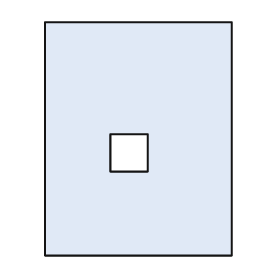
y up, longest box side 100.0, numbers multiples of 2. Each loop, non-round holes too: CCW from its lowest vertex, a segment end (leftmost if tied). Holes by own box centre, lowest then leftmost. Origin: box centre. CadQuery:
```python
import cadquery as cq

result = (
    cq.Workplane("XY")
    .moveTo(-40.0, -50.0)
    .lineTo(40.0, -50.0)
    .lineTo(40.0, 50.0)
    .lineTo(-40.0, 50.0)
    .close()
    .moveTo(-12.0, -14.0)
    .lineTo(4.0, -14.0)
    .lineTo(4.0, 2.0)
    .lineTo(-12.0, 2.0)
    .close()
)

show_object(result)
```